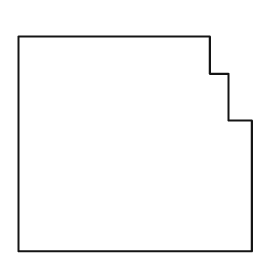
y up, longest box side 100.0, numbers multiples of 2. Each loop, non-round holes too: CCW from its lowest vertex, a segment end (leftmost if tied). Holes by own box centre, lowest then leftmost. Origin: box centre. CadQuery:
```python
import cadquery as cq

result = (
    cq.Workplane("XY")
    .moveTo(-50.0, -46.0)
    .lineTo(50.0, -46.0)
    .lineTo(50.0, 10.0)
    .lineTo(40.0, 10.0)
    .lineTo(40.0, 30.0)
    .lineTo(32.0, 30.0)
    .lineTo(32.0, 46.0)
    .lineTo(-50.0, 46.0)
    .close()
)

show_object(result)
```